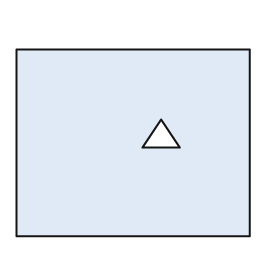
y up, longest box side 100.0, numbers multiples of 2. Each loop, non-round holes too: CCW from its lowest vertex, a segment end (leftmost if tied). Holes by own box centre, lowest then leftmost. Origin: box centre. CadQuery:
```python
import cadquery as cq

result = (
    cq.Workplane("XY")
    .moveTo(-50.0, -40.0)
    .lineTo(50.0, -40.0)
    .lineTo(50.0, 40.0)
    .lineTo(-50.0, 40.0)
    .close()
    .moveTo(4.0, -2.0)
    .lineTo(20.0, -2.0)
    .lineTo(12.0, 10.0)
    .close()
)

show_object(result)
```